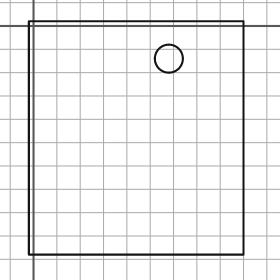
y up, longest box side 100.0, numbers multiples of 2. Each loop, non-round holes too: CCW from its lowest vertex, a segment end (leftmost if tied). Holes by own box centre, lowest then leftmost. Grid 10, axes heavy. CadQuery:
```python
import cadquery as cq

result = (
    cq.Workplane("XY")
    .moveTo(-2.0, -98.0)
    .lineTo(90.0, -98.0)
    .lineTo(90.0, 2.0)
    .lineTo(-2.0, 2.0)
    .close()
    .moveTo(58.0, -14.0)
    .circle(6.0)
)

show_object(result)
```